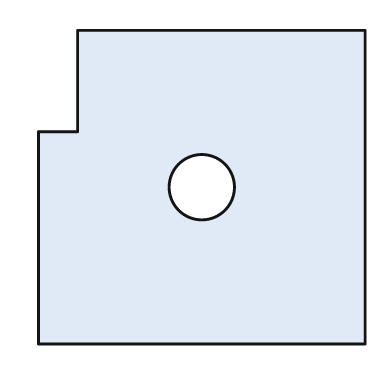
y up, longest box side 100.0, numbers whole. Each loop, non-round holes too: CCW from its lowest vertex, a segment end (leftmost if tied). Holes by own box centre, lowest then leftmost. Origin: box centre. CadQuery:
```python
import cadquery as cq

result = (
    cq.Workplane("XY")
    .moveTo(-50.0, -48.0)
    .lineTo(50.0, -48.0)
    .lineTo(50.0, 48.0)
    .lineTo(-38.0, 48.0)
    .lineTo(-38.0, 17.0)
    .lineTo(-50.0, 17.0)
    .close()
    .moveTo(0.0, 0.0)
    .circle(10.0)
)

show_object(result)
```